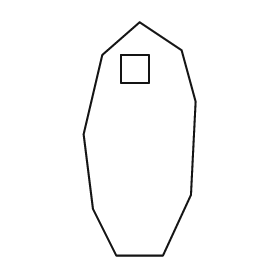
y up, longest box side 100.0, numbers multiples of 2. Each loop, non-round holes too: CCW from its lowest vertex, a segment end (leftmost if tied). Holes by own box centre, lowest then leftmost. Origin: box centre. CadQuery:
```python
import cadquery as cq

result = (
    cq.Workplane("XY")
    .moveTo(-10.0, -50.0)
    .lineTo(10.0, -50.0)
    .lineTo(22.0, -24.0)
    .lineTo(24.0, 16.0)
    .lineTo(18.0, 38.0)
    .lineTo(0.0, 50.0)
    .lineTo(-16.0, 36.0)
    .lineTo(-24.0, 2.0)
    .lineTo(-20.0, -30.0)
    .close()
    .moveTo(-8.0, 24.0)
    .lineTo(4.0, 24.0)
    .lineTo(4.0, 36.0)
    .lineTo(-8.0, 36.0)
    .close()
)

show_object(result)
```